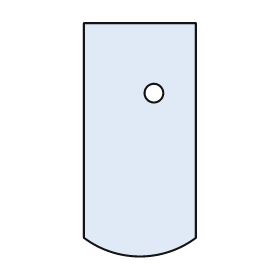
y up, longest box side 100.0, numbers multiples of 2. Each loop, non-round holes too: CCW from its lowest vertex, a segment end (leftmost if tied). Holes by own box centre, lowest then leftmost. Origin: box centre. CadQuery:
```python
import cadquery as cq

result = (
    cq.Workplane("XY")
    .moveTo(-24.0, -42.0)
    .threePointArc((0.0, -50.0), (24.0, -42.0))
    .lineTo(24.0, 50.0)
    .lineTo(-24.0, 50.0)
    .close()
    .moveTo(6.0, 20.0)
    .circle(4.0)
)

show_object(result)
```